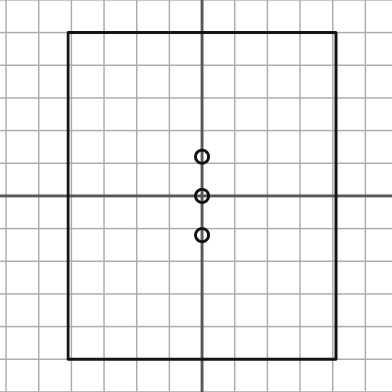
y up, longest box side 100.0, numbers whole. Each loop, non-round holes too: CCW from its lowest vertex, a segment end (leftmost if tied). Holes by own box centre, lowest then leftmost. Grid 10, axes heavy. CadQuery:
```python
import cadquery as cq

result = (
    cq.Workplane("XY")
    .moveTo(-41.0, -50.0)
    .lineTo(41.0, -50.0)
    .lineTo(41.0, 50.0)
    .lineTo(-41.0, 50.0)
    .close()
    .moveTo(0.0, -12.0)
    .circle(2.0)
    .moveTo(0.0, 0.0)
    .circle(2.0)
    .moveTo(0.0, 12.0)
    .circle(2.0)
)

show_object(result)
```